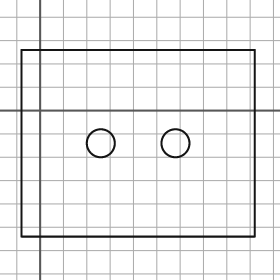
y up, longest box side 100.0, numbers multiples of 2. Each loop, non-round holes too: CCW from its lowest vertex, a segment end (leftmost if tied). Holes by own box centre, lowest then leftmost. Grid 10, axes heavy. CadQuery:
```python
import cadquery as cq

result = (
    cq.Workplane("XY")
    .moveTo(-8.0, -54.0)
    .lineTo(92.0, -54.0)
    .lineTo(92.0, 26.0)
    .lineTo(-8.0, 26.0)
    .close()
    .moveTo(26.0, -14.0)
    .circle(6.0)
    .moveTo(58.0, -14.0)
    .circle(6.0)
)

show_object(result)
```